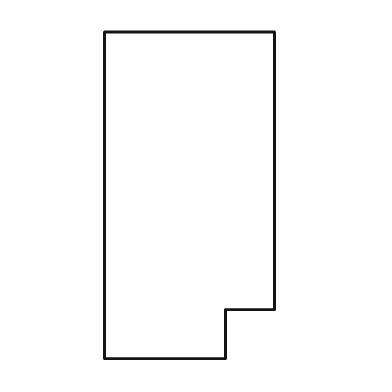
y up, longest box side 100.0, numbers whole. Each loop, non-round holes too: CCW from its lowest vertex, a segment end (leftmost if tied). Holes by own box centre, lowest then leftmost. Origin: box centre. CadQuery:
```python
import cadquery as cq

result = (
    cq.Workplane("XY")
    .moveTo(-26.0, -50.0)
    .lineTo(11.0, -50.0)
    .lineTo(11.0, -35.0)
    .lineTo(26.0, -35.0)
    .lineTo(26.0, 50.0)
    .lineTo(-26.0, 50.0)
    .close()
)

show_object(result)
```